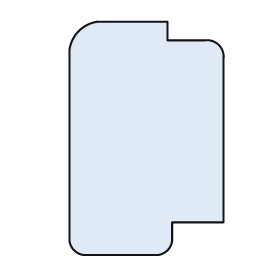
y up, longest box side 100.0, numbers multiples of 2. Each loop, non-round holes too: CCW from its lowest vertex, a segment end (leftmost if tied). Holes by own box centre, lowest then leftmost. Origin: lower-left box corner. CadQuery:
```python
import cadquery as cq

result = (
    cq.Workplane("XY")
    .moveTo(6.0, 0.0)
    .lineTo(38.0, 0.0)
    .threePointArc((42.0, 2.0), (44.0, 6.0))
    .lineTo(44.0, 14.0)
    .lineTo(66.0, 14.0)
    .lineTo(66.0, 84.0)
    .threePointArc((64.0, 90.0), (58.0, 92.0))
    .lineTo(42.0, 92.0)
    .lineTo(42.0, 100.0)
    .lineTo(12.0, 100.0)
    .threePointArc((4.0, 96.0), (0.0, 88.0))
    .lineTo(0.0, 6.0)
    .threePointArc((2.0, 2.0), (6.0, 0.0))
    .close()
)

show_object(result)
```